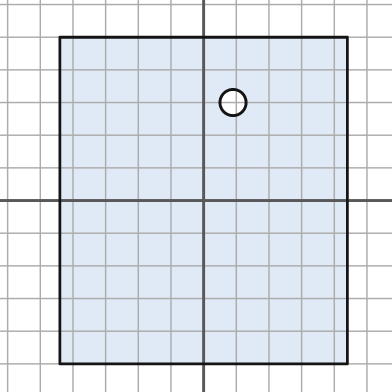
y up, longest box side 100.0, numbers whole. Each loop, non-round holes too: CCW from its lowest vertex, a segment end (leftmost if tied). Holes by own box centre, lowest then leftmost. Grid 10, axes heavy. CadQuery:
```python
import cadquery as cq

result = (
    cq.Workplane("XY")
    .moveTo(-44.0, -50.0)
    .lineTo(44.0, -50.0)
    .lineTo(44.0, 50.0)
    .lineTo(-44.0, 50.0)
    .close()
    .moveTo(9.0, 30.0)
    .circle(4.0)
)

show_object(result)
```